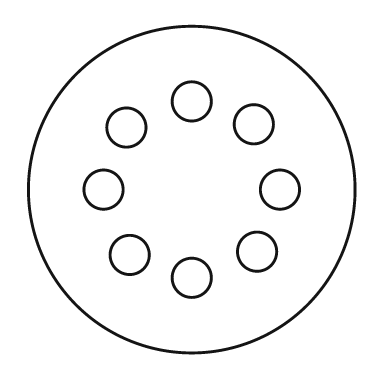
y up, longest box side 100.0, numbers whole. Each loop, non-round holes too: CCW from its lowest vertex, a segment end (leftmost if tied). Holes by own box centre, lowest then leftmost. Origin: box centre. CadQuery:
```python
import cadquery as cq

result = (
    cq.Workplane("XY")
    .moveTo(0.0, 0.0)
    .circle(50.0)
    .moveTo(0.0, -27.0)
    .circle(6.0)
    .moveTo(-19.0, -20.0)
    .circle(6.0)
    .moveTo(20.0, -19.0)
    .circle(6.0)
    .moveTo(-27.0, 0.0)
    .circle(6.0)
    .moveTo(27.0, 0.0)
    .circle(6.0)
    .moveTo(-20.0, 19.0)
    .circle(6.0)
    .moveTo(19.0, 20.0)
    .circle(6.0)
    .moveTo(0.0, 27.0)
    .circle(6.0)
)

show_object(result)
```